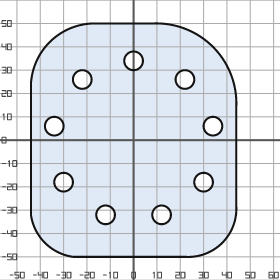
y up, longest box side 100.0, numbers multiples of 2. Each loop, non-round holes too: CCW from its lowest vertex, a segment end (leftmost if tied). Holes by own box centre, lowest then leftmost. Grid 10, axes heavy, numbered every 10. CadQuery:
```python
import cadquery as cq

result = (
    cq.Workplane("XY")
    .moveTo(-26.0, -50.0)
    .lineTo(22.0, -50.0)
    .threePointArc((38.0, -44.0), (44.0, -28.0))
    .lineTo(44.0, 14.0)
    .threePointArc((34.0, 40.0), (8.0, 50.0))
    .lineTo(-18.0, 50.0)
    .threePointArc((-36.0, 42.0), (-44.0, 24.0))
    .lineTo(-44.0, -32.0)
    .threePointArc((-38.0, -44.0), (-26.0, -50.0))
    .close()
    .moveTo(-12.0, -32.0)
    .circle(4.0)
    .moveTo(12.0, -32.0)
    .circle(4.0)
    .moveTo(-30.0, -18.0)
    .circle(4.0)
    .moveTo(30.0, -18.0)
    .circle(4.0)
    .moveTo(-34.0, 6.0)
    .circle(4.0)
    .moveTo(34.0, 6.0)
    .circle(4.0)
    .moveTo(-22.0, 26.0)
    .circle(4.0)
    .moveTo(22.0, 26.0)
    .circle(4.0)
    .moveTo(0.0, 34.0)
    .circle(4.0)
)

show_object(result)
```